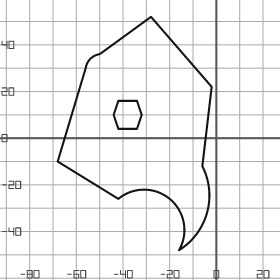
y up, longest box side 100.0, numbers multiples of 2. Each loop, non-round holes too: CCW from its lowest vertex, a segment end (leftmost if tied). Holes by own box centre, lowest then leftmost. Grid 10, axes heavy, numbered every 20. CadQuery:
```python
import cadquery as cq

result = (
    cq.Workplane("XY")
    .moveTo(-16.0, -48.0)
    .threePointArc((-4.0, -32.0), (-6.0, -12.0))
    .lineTo(-2.0, 22.0)
    .lineTo(-28.0, 52.0)
    .lineTo(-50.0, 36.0)
    .threePointArc((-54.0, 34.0), (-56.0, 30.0))
    .lineTo(-68.0, -10.0)
    .lineTo(-42.0, -26.0)
    .threePointArc((-20.0, -26.0), (-16.0, -48.0))
    .close()
    .moveTo(-42.0, 4.0)
    .lineTo(-34.0, 4.0)
    .lineTo(-32.0, 10.0)
    .lineTo(-34.0, 16.0)
    .lineTo(-42.0, 16.0)
    .lineTo(-44.0, 10.0)
    .close()
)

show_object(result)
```